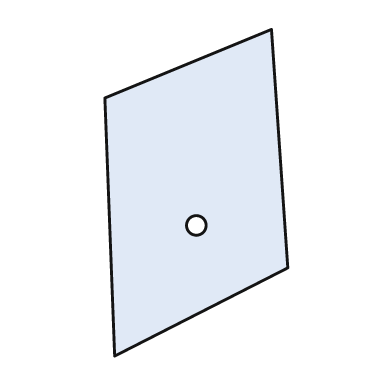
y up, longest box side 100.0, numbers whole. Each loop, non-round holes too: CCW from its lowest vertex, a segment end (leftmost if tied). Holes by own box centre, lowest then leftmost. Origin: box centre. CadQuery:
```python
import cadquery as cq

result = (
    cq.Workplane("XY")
    .moveTo(-25.0, -50.0)
    .lineTo(28.0, -23.0)
    .lineTo(23.0, 50.0)
    .lineTo(-28.0, 29.0)
    .close()
    .moveTo(0.0, -10.0)
    .circle(3.0)
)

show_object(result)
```